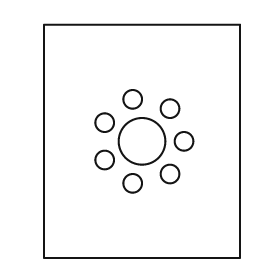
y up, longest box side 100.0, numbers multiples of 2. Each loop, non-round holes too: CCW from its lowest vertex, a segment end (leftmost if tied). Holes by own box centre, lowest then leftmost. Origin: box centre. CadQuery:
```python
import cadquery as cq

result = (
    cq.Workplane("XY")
    .moveTo(-42.0, -50.0)
    .lineTo(42.0, -50.0)
    .lineTo(42.0, 50.0)
    .lineTo(-42.0, 50.0)
    .close()
    .moveTo(-4.0, -18.0)
    .circle(4.0)
    .moveTo(12.0, -14.0)
    .circle(4.0)
    .moveTo(-16.0, -8.0)
    .circle(4.0)
    .moveTo(0.0, 0.0)
    .circle(10.0)
    .moveTo(18.0, 0.0)
    .circle(4.0)
    .moveTo(-16.0, 8.0)
    .circle(4.0)
    .moveTo(12.0, 14.0)
    .circle(4.0)
    .moveTo(-4.0, 18.0)
    .circle(4.0)
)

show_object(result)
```